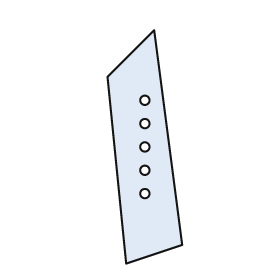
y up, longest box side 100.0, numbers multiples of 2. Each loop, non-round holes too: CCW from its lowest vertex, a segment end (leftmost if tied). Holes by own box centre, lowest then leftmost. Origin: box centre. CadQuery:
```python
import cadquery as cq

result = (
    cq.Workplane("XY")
    .moveTo(-8.0, -50.0)
    .lineTo(16.0, -42.0)
    .lineTo(4.0, 50.0)
    .lineTo(-16.0, 30.0)
    .close()
    .moveTo(0.0, -20.0)
    .circle(2.0)
    .moveTo(0.0, -10.0)
    .circle(2.0)
    .moveTo(0.0, 0.0)
    .circle(2.0)
    .moveTo(0.0, 10.0)
    .circle(2.0)
    .moveTo(0.0, 20.0)
    .circle(2.0)
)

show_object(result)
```